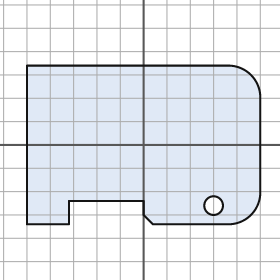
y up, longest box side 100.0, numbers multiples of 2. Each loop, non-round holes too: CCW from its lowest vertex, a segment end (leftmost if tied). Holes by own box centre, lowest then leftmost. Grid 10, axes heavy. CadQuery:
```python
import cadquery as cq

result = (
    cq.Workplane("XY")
    .moveTo(-50.0, -34.0)
    .lineTo(-32.0, -34.0)
    .lineTo(-32.0, -24.0)
    .lineTo(0.0, -24.0)
    .lineTo(0.0, -30.0)
    .lineTo(4.0, -34.0)
    .lineTo(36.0, -34.0)
    .threePointArc((46.0, -30.0), (50.0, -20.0))
    .lineTo(50.0, 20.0)
    .threePointArc((46.0, 30.0), (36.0, 34.0))
    .lineTo(-50.0, 34.0)
    .close()
    .moveTo(30.0, -26.0)
    .circle(4.0)
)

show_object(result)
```